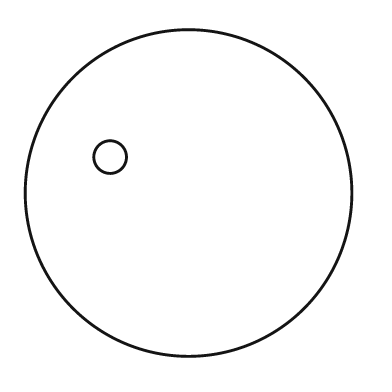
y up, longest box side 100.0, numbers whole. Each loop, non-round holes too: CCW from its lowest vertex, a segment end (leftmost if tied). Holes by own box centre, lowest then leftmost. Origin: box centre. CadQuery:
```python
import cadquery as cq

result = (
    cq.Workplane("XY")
    .moveTo(0.0, 0.0)
    .circle(50.0)
    .moveTo(-24.0, 11.0)
    .circle(5.0)
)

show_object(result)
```